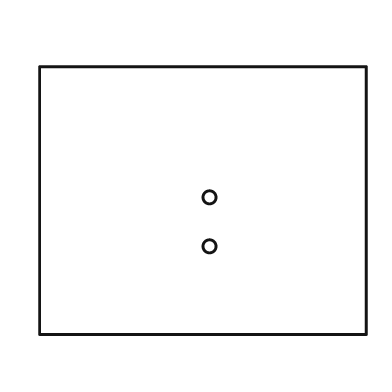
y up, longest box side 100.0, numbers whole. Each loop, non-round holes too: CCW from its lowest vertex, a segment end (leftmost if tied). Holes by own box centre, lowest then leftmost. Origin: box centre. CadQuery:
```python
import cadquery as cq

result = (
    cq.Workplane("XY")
    .moveTo(-50.0, -41.0)
    .lineTo(50.0, -41.0)
    .lineTo(50.0, 41.0)
    .lineTo(-50.0, 41.0)
    .close()
    .moveTo(2.0, -14.0)
    .circle(2.0)
    .moveTo(2.0, 1.0)
    .circle(2.0)
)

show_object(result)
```